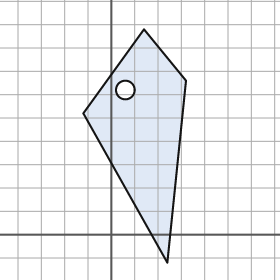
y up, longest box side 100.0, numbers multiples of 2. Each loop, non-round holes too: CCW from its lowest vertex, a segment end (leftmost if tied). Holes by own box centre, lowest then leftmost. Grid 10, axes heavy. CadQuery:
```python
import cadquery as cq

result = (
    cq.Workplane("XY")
    .moveTo(24.0, -12.0)
    .lineTo(32.0, 66.0)
    .lineTo(14.0, 88.0)
    .lineTo(-12.0, 52.0)
    .close()
    .moveTo(6.0, 62.0)
    .circle(4.0)
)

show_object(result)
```